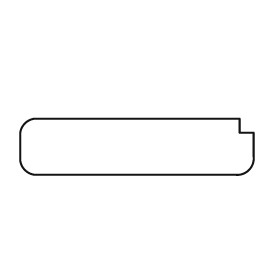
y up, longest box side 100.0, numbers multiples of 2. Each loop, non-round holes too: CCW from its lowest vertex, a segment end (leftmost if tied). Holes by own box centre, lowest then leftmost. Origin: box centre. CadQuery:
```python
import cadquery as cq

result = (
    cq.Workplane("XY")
    .moveTo(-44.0, -12.0)
    .lineTo(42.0, -12.0)
    .threePointArc((48.0, -10.0), (50.0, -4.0))
    .lineTo(50.0, 6.0)
    .lineTo(44.0, 6.0)
    .lineTo(44.0, 12.0)
    .lineTo(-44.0, 12.0)
    .threePointArc((-48.0, 10.0), (-50.0, 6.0))
    .lineTo(-50.0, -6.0)
    .threePointArc((-48.0, -10.0), (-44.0, -12.0))
    .close()
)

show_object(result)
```